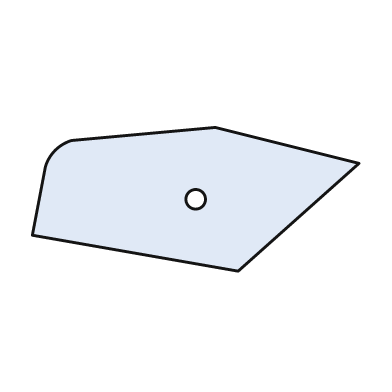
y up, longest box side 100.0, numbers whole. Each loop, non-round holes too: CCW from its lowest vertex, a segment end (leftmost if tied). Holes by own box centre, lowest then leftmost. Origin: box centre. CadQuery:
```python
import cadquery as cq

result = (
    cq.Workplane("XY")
    .moveTo(13.0, -22.0)
    .lineTo(50.0, 11.0)
    .lineTo(6.0, 22.0)
    .lineTo(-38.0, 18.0)
    .threePointArc((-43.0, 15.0), (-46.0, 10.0))
    .lineTo(-50.0, -11.0)
    .close()
    .moveTo(0.0, 0.0)
    .circle(3.0)
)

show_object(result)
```